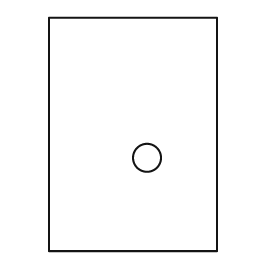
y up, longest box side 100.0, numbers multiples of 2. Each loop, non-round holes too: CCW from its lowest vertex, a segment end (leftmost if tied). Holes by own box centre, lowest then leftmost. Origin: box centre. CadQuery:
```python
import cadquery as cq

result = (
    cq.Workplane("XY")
    .moveTo(-36.0, -50.0)
    .lineTo(36.0, -50.0)
    .lineTo(36.0, 50.0)
    .lineTo(-36.0, 50.0)
    .close()
    .moveTo(6.0, -10.0)
    .circle(6.0)
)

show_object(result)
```